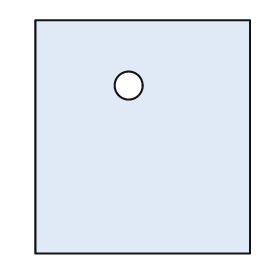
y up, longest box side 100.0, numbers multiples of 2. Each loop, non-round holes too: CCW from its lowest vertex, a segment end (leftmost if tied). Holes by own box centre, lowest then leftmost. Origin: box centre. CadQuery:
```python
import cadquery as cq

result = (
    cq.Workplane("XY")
    .moveTo(-46.0, -50.0)
    .lineTo(46.0, -50.0)
    .lineTo(46.0, 50.0)
    .lineTo(-46.0, 50.0)
    .close()
    .moveTo(-6.0, 22.0)
    .circle(6.0)
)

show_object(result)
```